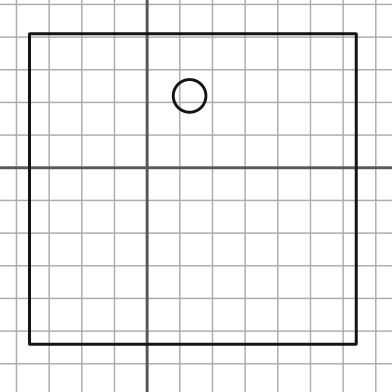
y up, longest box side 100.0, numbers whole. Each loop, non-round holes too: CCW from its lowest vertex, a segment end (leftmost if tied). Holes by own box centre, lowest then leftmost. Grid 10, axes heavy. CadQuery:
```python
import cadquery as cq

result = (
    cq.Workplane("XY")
    .moveTo(-36.0, -54.0)
    .lineTo(64.0, -54.0)
    .lineTo(64.0, 41.0)
    .lineTo(-36.0, 41.0)
    .close()
    .moveTo(13.0, 22.0)
    .circle(5.0)
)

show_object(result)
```